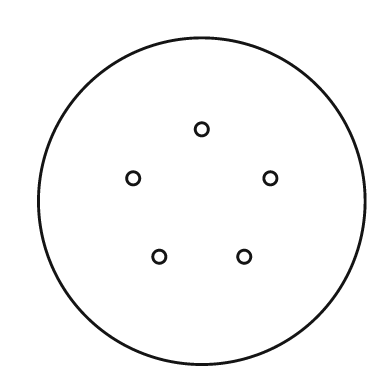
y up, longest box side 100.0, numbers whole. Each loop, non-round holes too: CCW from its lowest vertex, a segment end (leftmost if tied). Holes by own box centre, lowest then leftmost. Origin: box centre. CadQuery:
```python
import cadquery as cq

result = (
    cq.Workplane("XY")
    .moveTo(0.0, 0.0)
    .circle(50.0)
    .moveTo(-13.0, -17.0)
    .circle(2.0)
    .moveTo(13.0, -17.0)
    .circle(2.0)
    .moveTo(-21.0, 7.0)
    .circle(2.0)
    .moveTo(21.0, 7.0)
    .circle(2.0)
    .moveTo(0.0, 22.0)
    .circle(2.0)
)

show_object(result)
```